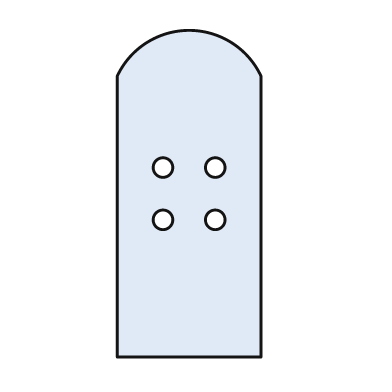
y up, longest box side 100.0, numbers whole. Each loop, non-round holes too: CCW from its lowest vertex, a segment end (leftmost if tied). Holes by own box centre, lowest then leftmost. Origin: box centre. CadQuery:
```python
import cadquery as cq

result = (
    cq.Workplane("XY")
    .moveTo(-22.0, -50.0)
    .lineTo(22.0, -50.0)
    .lineTo(22.0, 36.0)
    .threePointArc((0.0, 50.0), (-22.0, 36.0))
    .close()
    .moveTo(-8.0, -8.0)
    .circle(3.0)
    .moveTo(8.0, -8.0)
    .circle(3.0)
    .moveTo(-8.0, 8.0)
    .circle(3.0)
    .moveTo(8.0, 8.0)
    .circle(3.0)
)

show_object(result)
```